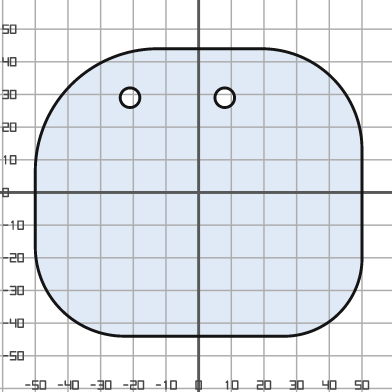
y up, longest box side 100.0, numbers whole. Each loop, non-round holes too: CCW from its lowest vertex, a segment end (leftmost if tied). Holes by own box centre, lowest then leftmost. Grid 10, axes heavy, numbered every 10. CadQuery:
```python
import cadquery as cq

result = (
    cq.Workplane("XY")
    .moveTo(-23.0, -44.0)
    .lineTo(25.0, -44.0)
    .threePointArc((43.0, -37.0), (50.0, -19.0))
    .lineTo(50.0, 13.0)
    .threePointArc((41.0, 35.0), (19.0, 44.0))
    .lineTo(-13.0, 44.0)
    .threePointArc((-39.0, 33.0), (-50.0, 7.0))
    .lineTo(-50.0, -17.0)
    .threePointArc((-42.0, -36.0), (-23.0, -44.0))
    .close()
    .moveTo(-21.0, 29.0)
    .circle(3.0)
    .moveTo(8.0, 29.0)
    .circle(3.0)
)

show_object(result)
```